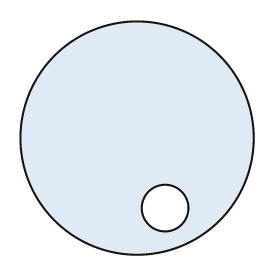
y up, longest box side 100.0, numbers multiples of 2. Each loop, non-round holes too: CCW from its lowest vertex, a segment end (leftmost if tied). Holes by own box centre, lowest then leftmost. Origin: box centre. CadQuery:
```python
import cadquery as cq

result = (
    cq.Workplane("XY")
    .moveTo(0.0, 0.0)
    .circle(50.0)
    .moveTo(12.0, -30.0)
    .circle(10.0)
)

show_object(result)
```